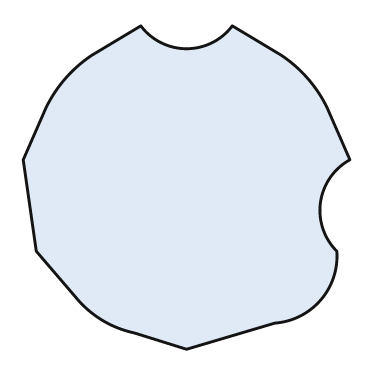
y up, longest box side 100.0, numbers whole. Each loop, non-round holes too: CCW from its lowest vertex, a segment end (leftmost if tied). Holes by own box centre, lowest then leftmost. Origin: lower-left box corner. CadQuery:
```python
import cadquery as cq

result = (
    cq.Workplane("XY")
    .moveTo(50.0, 0.0)
    .lineTo(77.0, 8.0)
    .threePointArc((91.0, 15.0), (96.0, 30.0))
    .threePointArc((91.0, 45.0), (100.0, 58.0))
    .lineTo(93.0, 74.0)
    .threePointArc((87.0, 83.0), (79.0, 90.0))
    .lineTo(64.0, 99.0)
    .threePointArc((50.0, 92.0), (36.0, 99.0))
    .lineTo(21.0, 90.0)
    .threePointArc((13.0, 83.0), (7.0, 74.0))
    .lineTo(0.0, 58.0)
    .lineTo(4.0, 30.0)
    .lineTo(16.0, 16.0)
    .threePointArc((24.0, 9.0), (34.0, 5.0))
    .close()
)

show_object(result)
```